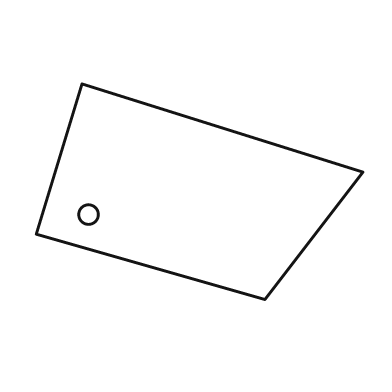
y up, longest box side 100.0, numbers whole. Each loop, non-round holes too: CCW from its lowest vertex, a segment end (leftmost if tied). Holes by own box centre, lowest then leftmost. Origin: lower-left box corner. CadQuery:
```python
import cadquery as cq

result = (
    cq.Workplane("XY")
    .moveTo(70.0, 0.0)
    .lineTo(100.0, 39.0)
    .lineTo(14.0, 66.0)
    .lineTo(0.0, 20.0)
    .close()
    .moveTo(16.0, 26.0)
    .circle(3.0)
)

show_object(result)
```